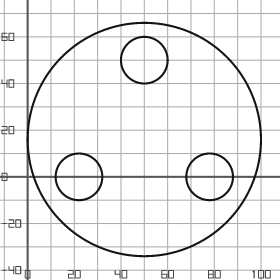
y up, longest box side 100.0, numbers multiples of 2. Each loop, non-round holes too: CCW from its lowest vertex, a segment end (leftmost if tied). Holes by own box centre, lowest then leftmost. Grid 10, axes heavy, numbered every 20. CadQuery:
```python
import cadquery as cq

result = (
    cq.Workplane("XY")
    .moveTo(50.0, 16.0)
    .circle(50.0)
    .moveTo(22.0, 0.0)
    .circle(10.0)
    .moveTo(78.0, 0.0)
    .circle(10.0)
    .moveTo(50.0, 50.0)
    .circle(10.0)
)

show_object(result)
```